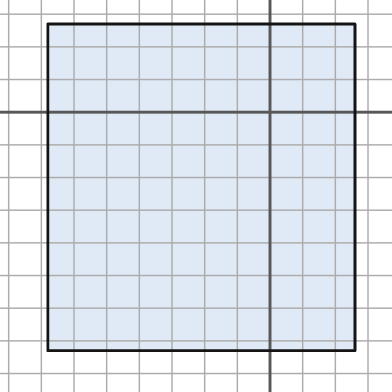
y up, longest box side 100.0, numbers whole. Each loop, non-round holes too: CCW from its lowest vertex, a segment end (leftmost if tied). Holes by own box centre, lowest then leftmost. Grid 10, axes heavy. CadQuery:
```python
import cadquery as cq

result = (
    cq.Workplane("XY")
    .moveTo(-68.0, -73.0)
    .lineTo(26.0, -73.0)
    .lineTo(26.0, 27.0)
    .lineTo(-68.0, 27.0)
    .close()
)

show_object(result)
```